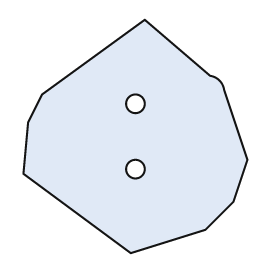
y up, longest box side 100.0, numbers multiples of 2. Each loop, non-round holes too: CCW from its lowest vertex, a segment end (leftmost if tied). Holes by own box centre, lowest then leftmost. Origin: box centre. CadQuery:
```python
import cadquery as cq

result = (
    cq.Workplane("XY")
    .moveTo(-2.0, -50.0)
    .lineTo(30.0, -40.0)
    .lineTo(42.0, -28.0)
    .lineTo(48.0, -10.0)
    .lineTo(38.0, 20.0)
    .threePointArc((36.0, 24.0), (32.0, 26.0))
    .lineTo(4.0, 50.0)
    .lineTo(-40.0, 18.0)
    .lineTo(-46.0, 6.0)
    .lineTo(-48.0, -16.0)
    .close()
    .moveTo(0.0, -14.0)
    .circle(4.0)
    .moveTo(0.0, 14.0)
    .circle(4.0)
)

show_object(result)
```